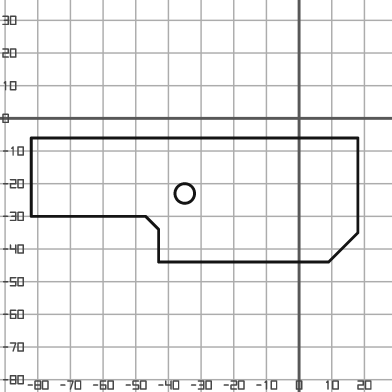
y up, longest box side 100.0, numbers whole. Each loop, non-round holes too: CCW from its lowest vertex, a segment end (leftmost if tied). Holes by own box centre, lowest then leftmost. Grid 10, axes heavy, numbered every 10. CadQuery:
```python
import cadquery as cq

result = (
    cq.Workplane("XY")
    .moveTo(-43.0, -44.0)
    .lineTo(9.0, -44.0)
    .lineTo(18.0, -35.0)
    .lineTo(18.0, -6.0)
    .lineTo(-82.0, -6.0)
    .lineTo(-82.0, -30.0)
    .lineTo(-47.0, -30.0)
    .lineTo(-43.0, -34.0)
    .close()
    .moveTo(-35.0, -23.0)
    .circle(3.0)
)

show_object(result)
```